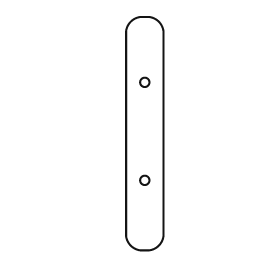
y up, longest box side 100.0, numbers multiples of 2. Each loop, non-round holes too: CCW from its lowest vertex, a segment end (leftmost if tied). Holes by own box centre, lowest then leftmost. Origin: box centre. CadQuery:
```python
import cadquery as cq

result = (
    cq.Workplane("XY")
    .moveTo(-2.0, -50.0)
    .lineTo(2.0, -50.0)
    .threePointArc((6.0, -48.0), (8.0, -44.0))
    .lineTo(8.0, 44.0)
    .threePointArc((6.0, 48.0), (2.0, 50.0))
    .lineTo(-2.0, 50.0)
    .threePointArc((-6.0, 48.0), (-8.0, 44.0))
    .lineTo(-8.0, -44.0)
    .threePointArc((-6.0, -48.0), (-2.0, -50.0))
    .close()
    .moveTo(0.0, -20.0)
    .circle(2.0)
    .moveTo(0.0, 22.0)
    .circle(2.0)
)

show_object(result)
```